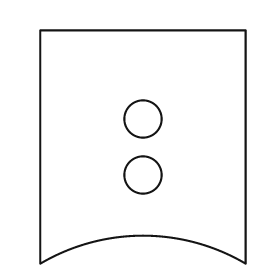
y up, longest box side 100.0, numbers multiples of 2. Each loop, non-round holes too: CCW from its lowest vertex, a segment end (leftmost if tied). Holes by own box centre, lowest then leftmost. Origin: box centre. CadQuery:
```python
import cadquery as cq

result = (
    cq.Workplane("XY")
    .moveTo(-44.0, -50.0)
    .threePointArc((0.0, -38.0), (44.0, -50.0))
    .lineTo(44.0, 50.0)
    .lineTo(-44.0, 50.0)
    .close()
    .moveTo(0.0, -12.0)
    .circle(8.0)
    .moveTo(0.0, 12.0)
    .circle(8.0)
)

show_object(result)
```